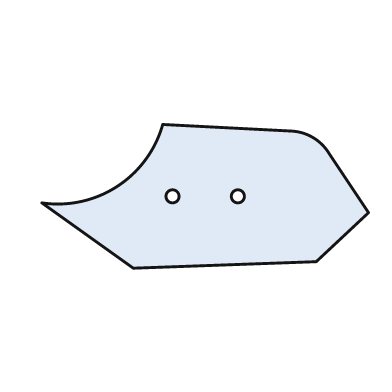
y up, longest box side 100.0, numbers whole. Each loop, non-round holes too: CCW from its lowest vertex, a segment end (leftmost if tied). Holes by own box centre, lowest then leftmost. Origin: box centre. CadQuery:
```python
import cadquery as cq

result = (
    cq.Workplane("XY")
    .moveTo(-22.0, -22.0)
    .lineTo(34.0, -20.0)
    .lineTo(50.0, -5.0)
    .lineTo(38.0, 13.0)
    .threePointArc((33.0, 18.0), (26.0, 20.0))
    .lineTo(-13.0, 22.0)
    .threePointArc((-27.0, 3.0), (-50.0, -2.0))
    .close()
    .moveTo(-10.0, 0.0)
    .circle(2.0)
    .moveTo(10.0, 0.0)
    .circle(2.0)
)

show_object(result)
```